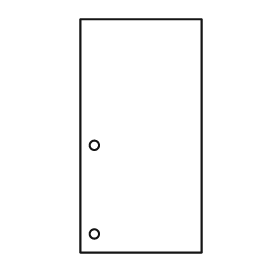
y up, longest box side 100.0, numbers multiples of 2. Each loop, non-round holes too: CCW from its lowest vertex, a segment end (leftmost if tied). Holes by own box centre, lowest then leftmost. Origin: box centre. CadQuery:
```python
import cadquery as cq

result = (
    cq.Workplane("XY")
    .moveTo(-26.0, -50.0)
    .lineTo(26.0, -50.0)
    .lineTo(26.0, 50.0)
    .lineTo(-26.0, 50.0)
    .close()
    .moveTo(-20.0, -42.0)
    .circle(2.0)
    .moveTo(-20.0, -4.0)
    .circle(2.0)
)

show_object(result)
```